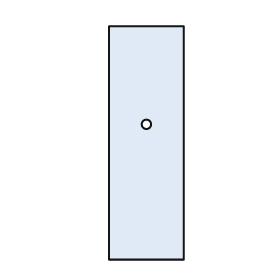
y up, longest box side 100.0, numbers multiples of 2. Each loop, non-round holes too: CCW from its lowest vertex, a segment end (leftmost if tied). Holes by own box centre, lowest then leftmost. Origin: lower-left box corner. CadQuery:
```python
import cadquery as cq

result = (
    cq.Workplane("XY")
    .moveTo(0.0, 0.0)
    .lineTo(32.0, 0.0)
    .lineTo(32.0, 100.0)
    .lineTo(0.0, 100.0)
    .close()
    .moveTo(16.0, 58.0)
    .circle(2.0)
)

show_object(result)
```